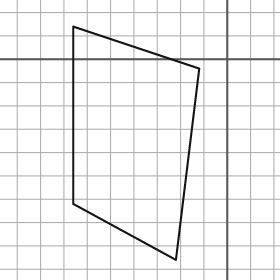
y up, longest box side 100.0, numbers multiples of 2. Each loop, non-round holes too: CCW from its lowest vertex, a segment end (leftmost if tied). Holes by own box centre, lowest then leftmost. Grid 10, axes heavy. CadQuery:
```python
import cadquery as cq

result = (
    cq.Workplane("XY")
    .moveTo(-22.0, -86.0)
    .lineTo(-12.0, -4.0)
    .lineTo(-66.0, 14.0)
    .lineTo(-66.0, -62.0)
    .close()
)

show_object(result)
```